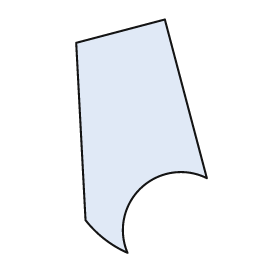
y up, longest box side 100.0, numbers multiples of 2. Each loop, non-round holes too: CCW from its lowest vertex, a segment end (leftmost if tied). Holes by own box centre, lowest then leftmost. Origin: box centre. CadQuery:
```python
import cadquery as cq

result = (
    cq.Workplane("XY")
    .moveTo(-6.0, -50.0)
    .threePointArc((0.0, -22.0), (28.0, -18.0))
    .lineTo(10.0, 50.0)
    .lineTo(-28.0, 40.0)
    .lineTo(-24.0, -36.0)
    .threePointArc((-16.0, -44.0), (-6.0, -50.0))
    .close()
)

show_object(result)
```